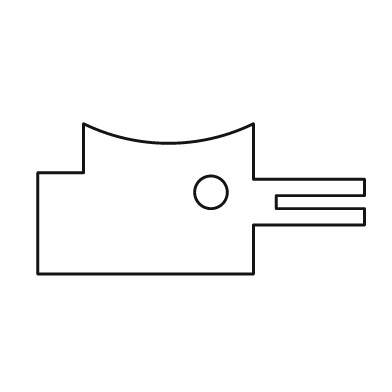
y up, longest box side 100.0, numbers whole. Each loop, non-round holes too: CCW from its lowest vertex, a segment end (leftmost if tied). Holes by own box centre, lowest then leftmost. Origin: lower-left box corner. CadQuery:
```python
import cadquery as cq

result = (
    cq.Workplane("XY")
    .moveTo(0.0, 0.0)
    .lineTo(66.0, 0.0)
    .lineTo(66.0, 15.0)
    .lineTo(100.0, 15.0)
    .lineTo(100.0, 20.0)
    .lineTo(73.0, 20.0)
    .lineTo(73.0, 24.0)
    .lineTo(100.0, 24.0)
    .lineTo(100.0, 29.0)
    .lineTo(66.0, 29.0)
    .lineTo(66.0, 46.0)
    .threePointArc((40.0, 40.0), (14.0, 46.0))
    .lineTo(14.0, 31.0)
    .lineTo(0.0, 31.0)
    .close()
    .moveTo(53.0, 25.0)
    .circle(5.0)
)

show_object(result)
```